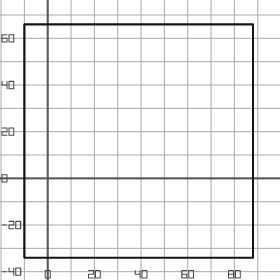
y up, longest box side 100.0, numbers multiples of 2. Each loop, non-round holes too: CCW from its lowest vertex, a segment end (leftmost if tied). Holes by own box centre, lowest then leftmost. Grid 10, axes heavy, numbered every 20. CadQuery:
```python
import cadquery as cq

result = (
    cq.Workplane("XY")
    .moveTo(-10.0, -34.0)
    .lineTo(88.0, -34.0)
    .lineTo(88.0, 66.0)
    .lineTo(-10.0, 66.0)
    .close()
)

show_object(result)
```